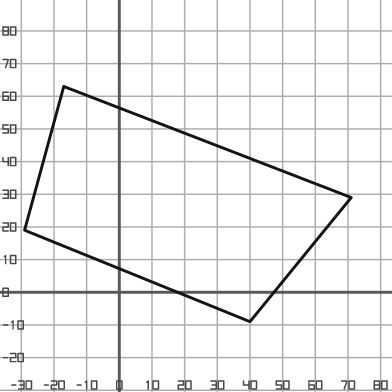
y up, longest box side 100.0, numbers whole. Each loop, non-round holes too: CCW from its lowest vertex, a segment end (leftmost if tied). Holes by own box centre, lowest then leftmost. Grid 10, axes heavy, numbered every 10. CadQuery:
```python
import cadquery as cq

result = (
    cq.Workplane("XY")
    .moveTo(40.0, -9.0)
    .lineTo(71.0, 29.0)
    .lineTo(-17.0, 63.0)
    .lineTo(-29.0, 19.0)
    .close()
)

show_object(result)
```